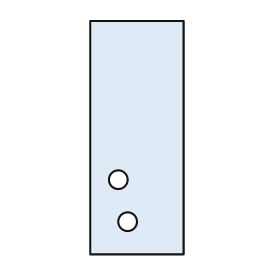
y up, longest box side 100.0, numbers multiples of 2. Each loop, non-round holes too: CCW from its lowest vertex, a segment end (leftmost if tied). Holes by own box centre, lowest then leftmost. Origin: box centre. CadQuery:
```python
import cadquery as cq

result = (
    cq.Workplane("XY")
    .moveTo(-20.0, -50.0)
    .lineTo(20.0, -50.0)
    .lineTo(20.0, 50.0)
    .lineTo(-20.0, 50.0)
    .close()
    .moveTo(-4.0, -36.0)
    .circle(4.0)
    .moveTo(-8.0, -18.0)
    .circle(4.0)
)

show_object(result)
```